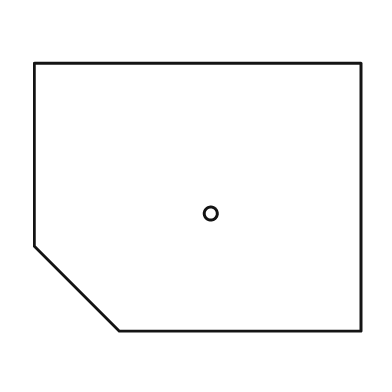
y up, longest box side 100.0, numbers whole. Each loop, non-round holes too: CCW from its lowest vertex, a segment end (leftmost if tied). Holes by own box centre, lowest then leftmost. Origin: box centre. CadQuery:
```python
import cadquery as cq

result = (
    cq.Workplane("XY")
    .moveTo(-24.0, -41.0)
    .lineTo(50.0, -41.0)
    .lineTo(50.0, 41.0)
    .lineTo(-50.0, 41.0)
    .lineTo(-50.0, -15.0)
    .close()
    .moveTo(4.0, -5.0)
    .circle(2.0)
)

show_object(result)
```